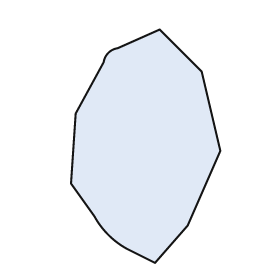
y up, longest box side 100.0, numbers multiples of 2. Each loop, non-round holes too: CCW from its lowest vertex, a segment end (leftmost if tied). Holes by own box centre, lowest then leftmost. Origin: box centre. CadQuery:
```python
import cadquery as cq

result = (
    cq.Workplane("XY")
    .moveTo(4.0, -50.0)
    .lineTo(18.0, -34.0)
    .lineTo(32.0, -2.0)
    .lineTo(24.0, 32.0)
    .lineTo(6.0, 50.0)
    .lineTo(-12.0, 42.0)
    .threePointArc((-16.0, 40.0), (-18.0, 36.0))
    .lineTo(-30.0, 14.0)
    .lineTo(-32.0, -16.0)
    .lineTo(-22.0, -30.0)
    .threePointArc((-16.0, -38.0), (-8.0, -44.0))
    .close()
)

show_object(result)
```